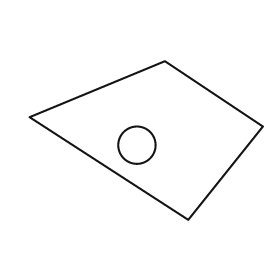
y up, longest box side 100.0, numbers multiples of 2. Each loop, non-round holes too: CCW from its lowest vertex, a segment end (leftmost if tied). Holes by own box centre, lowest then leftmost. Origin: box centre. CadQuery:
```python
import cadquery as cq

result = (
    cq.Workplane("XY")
    .moveTo(18.0, -34.0)
    .lineTo(50.0, 6.0)
    .lineTo(8.0, 34.0)
    .lineTo(-50.0, 10.0)
    .close()
    .moveTo(-4.0, -2.0)
    .circle(8.0)
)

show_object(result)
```